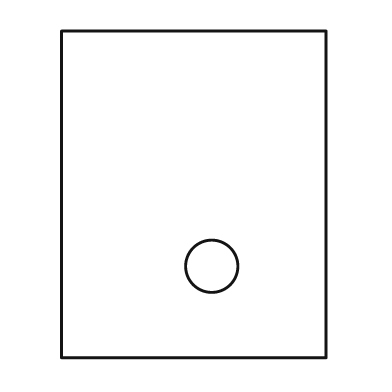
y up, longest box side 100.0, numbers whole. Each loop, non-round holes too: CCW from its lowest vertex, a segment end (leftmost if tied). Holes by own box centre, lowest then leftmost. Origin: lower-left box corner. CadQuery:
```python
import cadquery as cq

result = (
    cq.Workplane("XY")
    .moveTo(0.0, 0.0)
    .lineTo(81.0, 0.0)
    .lineTo(81.0, 100.0)
    .lineTo(0.0, 100.0)
    .close()
    .moveTo(46.0, 28.0)
    .circle(8.0)
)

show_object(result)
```